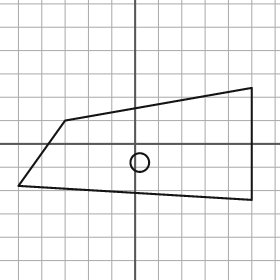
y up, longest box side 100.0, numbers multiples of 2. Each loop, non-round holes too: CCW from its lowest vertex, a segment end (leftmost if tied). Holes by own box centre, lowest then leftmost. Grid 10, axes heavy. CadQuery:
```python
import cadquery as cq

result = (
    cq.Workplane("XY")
    .moveTo(50.0, -24.0)
    .lineTo(50.0, 24.0)
    .lineTo(-30.0, 10.0)
    .lineTo(-50.0, -18.0)
    .close()
    .moveTo(2.0, -8.0)
    .circle(4.0)
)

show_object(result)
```